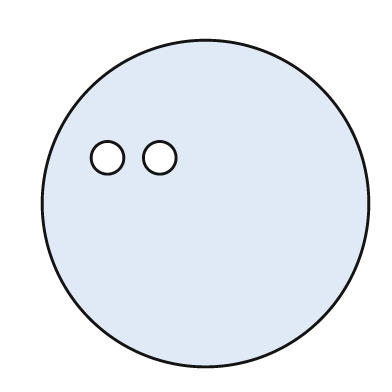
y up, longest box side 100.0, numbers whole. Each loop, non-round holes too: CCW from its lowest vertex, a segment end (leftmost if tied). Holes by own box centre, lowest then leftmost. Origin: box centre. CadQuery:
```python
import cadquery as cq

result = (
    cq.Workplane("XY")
    .moveTo(0.0, 0.0)
    .circle(50.0)
    .moveTo(-30.0, 14.0)
    .circle(5.0)
    .moveTo(-14.0, 14.0)
    .circle(5.0)
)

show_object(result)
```